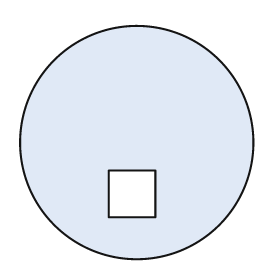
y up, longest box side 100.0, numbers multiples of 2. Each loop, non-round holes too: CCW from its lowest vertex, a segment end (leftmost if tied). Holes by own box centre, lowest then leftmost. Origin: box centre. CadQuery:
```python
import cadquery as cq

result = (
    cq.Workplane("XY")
    .moveTo(0.0, 0.0)
    .circle(50.0)
    .moveTo(-12.0, -32.0)
    .lineTo(8.0, -32.0)
    .lineTo(8.0, -12.0)
    .lineTo(-12.0, -12.0)
    .close()
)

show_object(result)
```